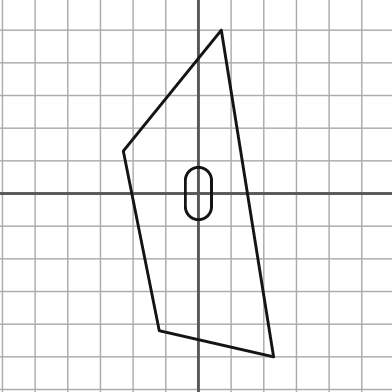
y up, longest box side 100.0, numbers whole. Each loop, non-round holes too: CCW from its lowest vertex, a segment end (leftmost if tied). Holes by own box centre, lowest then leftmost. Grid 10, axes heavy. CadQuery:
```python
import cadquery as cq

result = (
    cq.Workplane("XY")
    .moveTo(23.0, -50.0)
    .lineTo(7.0, 50.0)
    .lineTo(-23.0, 13.0)
    .lineTo(-12.0, -42.0)
    .close()
    .moveTo(-4.0, -4.0)
    .threePointArc((0.0, -8.0), (4.0, -4.0))
    .lineTo(4.0, 4.0)
    .threePointArc((0.0, 8.0), (-4.0, 4.0))
    .close()
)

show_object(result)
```